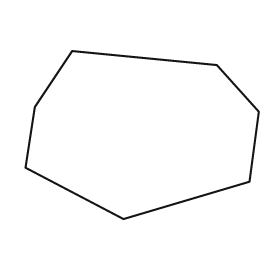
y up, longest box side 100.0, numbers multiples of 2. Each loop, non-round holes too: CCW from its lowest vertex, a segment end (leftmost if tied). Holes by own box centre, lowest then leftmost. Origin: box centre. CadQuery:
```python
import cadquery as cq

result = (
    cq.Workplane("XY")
    .moveTo(-8.0, -36.0)
    .lineTo(46.0, -20.0)
    .lineTo(50.0, 10.0)
    .lineTo(32.0, 30.0)
    .lineTo(-30.0, 36.0)
    .lineTo(-46.0, 12.0)
    .lineTo(-50.0, -14.0)
    .close()
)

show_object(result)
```